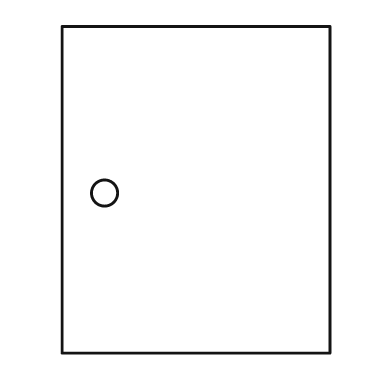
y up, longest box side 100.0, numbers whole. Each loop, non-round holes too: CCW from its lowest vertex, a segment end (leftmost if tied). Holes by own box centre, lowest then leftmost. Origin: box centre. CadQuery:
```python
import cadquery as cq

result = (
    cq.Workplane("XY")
    .moveTo(-41.0, -50.0)
    .lineTo(41.0, -50.0)
    .lineTo(41.0, 50.0)
    .lineTo(-41.0, 50.0)
    .close()
    .moveTo(-28.0, -1.0)
    .circle(4.0)
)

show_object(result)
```